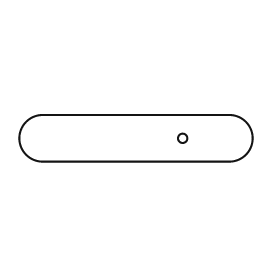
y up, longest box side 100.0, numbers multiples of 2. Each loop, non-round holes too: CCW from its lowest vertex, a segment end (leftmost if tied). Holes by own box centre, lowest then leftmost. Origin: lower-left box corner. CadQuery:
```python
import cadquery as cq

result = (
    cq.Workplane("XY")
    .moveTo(10.0, 0.0)
    .lineTo(90.0, 0.0)
    .threePointArc((100.0, 10.0), (90.0, 20.0))
    .lineTo(10.0, 20.0)
    .threePointArc((0.0, 10.0), (10.0, 0.0))
    .close()
    .moveTo(70.0, 10.0)
    .circle(2.0)
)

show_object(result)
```